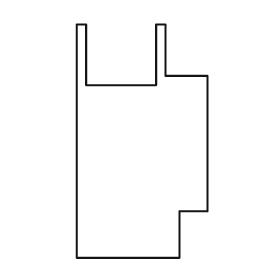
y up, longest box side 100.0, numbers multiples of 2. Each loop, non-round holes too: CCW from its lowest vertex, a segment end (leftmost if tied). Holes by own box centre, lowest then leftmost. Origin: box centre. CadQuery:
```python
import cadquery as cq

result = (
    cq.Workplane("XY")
    .moveTo(-28.0, -50.0)
    .lineTo(16.0, -50.0)
    .lineTo(16.0, -30.0)
    .lineTo(28.0, -30.0)
    .lineTo(28.0, 28.0)
    .lineTo(10.0, 28.0)
    .lineTo(10.0, 50.0)
    .lineTo(6.0, 50.0)
    .lineTo(6.0, 24.0)
    .lineTo(-24.0, 24.0)
    .lineTo(-24.0, 50.0)
    .lineTo(-28.0, 50.0)
    .close()
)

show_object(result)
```